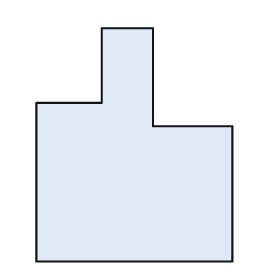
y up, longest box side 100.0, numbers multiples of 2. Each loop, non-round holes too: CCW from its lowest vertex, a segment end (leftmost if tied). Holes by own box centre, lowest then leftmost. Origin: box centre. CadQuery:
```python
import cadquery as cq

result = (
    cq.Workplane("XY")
    .moveTo(-42.0, -50.0)
    .lineTo(42.0, -50.0)
    .lineTo(42.0, 8.0)
    .lineTo(8.0, 8.0)
    .lineTo(8.0, 50.0)
    .lineTo(-14.0, 50.0)
    .lineTo(-14.0, 18.0)
    .lineTo(-42.0, 18.0)
    .close()
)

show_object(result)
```